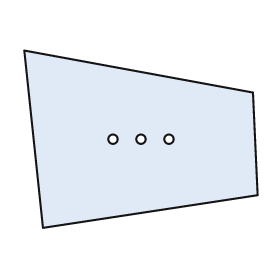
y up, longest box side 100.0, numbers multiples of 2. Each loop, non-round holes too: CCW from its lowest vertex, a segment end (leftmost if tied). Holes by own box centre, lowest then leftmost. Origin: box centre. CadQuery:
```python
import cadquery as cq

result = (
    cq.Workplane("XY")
    .moveTo(-42.0, -38.0)
    .lineTo(50.0, -24.0)
    .lineTo(48.0, 20.0)
    .lineTo(-50.0, 38.0)
    .close()
    .moveTo(-12.0, 0.0)
    .circle(2.0)
    .moveTo(0.0, 0.0)
    .circle(2.0)
    .moveTo(12.0, 0.0)
    .circle(2.0)
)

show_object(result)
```